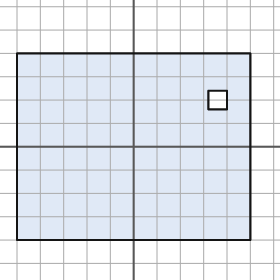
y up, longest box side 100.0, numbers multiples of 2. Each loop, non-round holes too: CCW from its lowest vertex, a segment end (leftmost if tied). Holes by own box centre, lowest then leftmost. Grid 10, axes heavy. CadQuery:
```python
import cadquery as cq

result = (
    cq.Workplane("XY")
    .moveTo(-50.0, -40.0)
    .lineTo(50.0, -40.0)
    .lineTo(50.0, 40.0)
    .lineTo(-50.0, 40.0)
    .close()
    .moveTo(32.0, 16.0)
    .lineTo(40.0, 16.0)
    .lineTo(40.0, 24.0)
    .lineTo(32.0, 24.0)
    .close()
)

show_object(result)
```